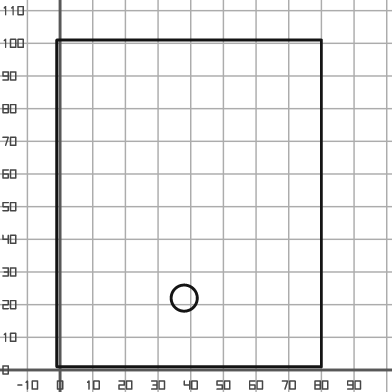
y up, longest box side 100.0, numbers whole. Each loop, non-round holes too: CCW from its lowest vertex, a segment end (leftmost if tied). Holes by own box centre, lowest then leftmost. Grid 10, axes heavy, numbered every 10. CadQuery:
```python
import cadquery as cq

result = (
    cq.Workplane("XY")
    .moveTo(-1.0, 1.0)
    .lineTo(80.0, 1.0)
    .lineTo(80.0, 101.0)
    .lineTo(-1.0, 101.0)
    .close()
    .moveTo(38.0, 22.0)
    .circle(4.0)
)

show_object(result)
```